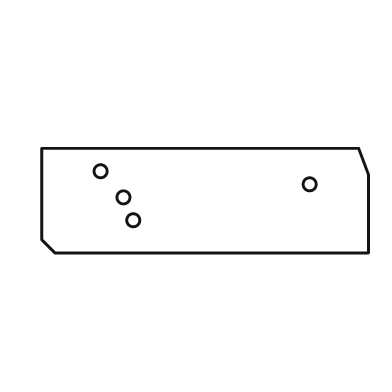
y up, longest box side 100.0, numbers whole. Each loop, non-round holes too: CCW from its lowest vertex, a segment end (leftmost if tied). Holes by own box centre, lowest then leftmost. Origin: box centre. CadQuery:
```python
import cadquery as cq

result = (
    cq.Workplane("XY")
    .moveTo(-46.0, -16.0)
    .lineTo(50.0, -16.0)
    .lineTo(50.0, 8.0)
    .lineTo(47.0, 16.0)
    .lineTo(-50.0, 16.0)
    .lineTo(-50.0, -12.0)
    .close()
    .moveTo(-22.0, -6.0)
    .circle(2.0)
    .moveTo(-25.0, 1.0)
    .circle(2.0)
    .moveTo(32.0, 5.0)
    .circle(2.0)
    .moveTo(-32.0, 9.0)
    .circle(2.0)
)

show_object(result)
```